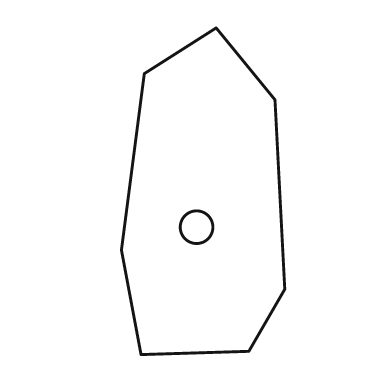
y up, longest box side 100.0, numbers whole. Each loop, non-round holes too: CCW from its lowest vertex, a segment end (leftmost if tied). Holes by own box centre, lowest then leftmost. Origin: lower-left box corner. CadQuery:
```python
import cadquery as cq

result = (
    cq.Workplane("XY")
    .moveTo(6.0, 0.0)
    .lineTo(39.0, 1.0)
    .lineTo(50.0, 20.0)
    .lineTo(47.0, 78.0)
    .lineTo(29.0, 100.0)
    .lineTo(7.0, 86.0)
    .lineTo(0.0, 32.0)
    .close()
    .moveTo(23.0, 39.0)
    .circle(5.0)
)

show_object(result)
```